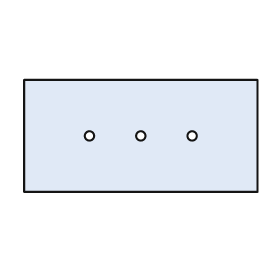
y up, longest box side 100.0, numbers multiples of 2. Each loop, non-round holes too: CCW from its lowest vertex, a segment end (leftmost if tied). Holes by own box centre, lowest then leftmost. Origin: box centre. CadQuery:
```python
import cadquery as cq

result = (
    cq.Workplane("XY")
    .moveTo(-50.0, -24.0)
    .lineTo(50.0, -24.0)
    .lineTo(50.0, 24.0)
    .lineTo(-50.0, 24.0)
    .close()
    .moveTo(-22.0, 0.0)
    .circle(2.0)
    .moveTo(0.0, 0.0)
    .circle(2.0)
    .moveTo(22.0, 0.0)
    .circle(2.0)
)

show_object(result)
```